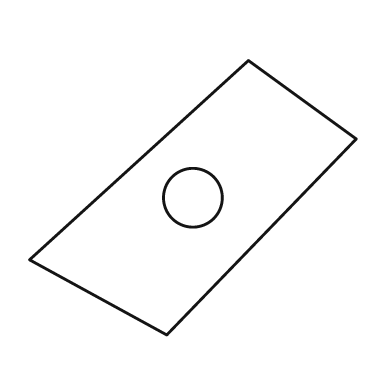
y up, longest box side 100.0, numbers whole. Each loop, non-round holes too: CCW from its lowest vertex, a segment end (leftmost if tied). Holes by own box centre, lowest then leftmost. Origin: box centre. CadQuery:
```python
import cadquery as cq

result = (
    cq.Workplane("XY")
    .moveTo(-8.0, -42.0)
    .lineTo(50.0, 18.0)
    .lineTo(17.0, 42.0)
    .lineTo(-50.0, -19.0)
    .close()
    .moveTo(0.0, 0.0)
    .circle(9.0)
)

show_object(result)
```